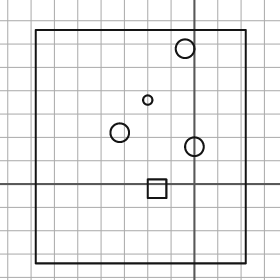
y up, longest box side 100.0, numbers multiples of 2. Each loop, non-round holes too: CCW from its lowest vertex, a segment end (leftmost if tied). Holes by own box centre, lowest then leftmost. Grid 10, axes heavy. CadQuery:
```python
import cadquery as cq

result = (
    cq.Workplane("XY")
    .moveTo(-68.0, -34.0)
    .lineTo(22.0, -34.0)
    .lineTo(22.0, 66.0)
    .lineTo(-68.0, 66.0)
    .close()
    .moveTo(-20.0, -6.0)
    .lineTo(-12.0, -6.0)
    .lineTo(-12.0, 2.0)
    .lineTo(-20.0, 2.0)
    .close()
    .moveTo(0.0, 16.0)
    .circle(4.0)
    .moveTo(-32.0, 22.0)
    .circle(4.0)
    .moveTo(-20.0, 36.0)
    .circle(2.0)
    .moveTo(-4.0, 58.0)
    .circle(4.0)
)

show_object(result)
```